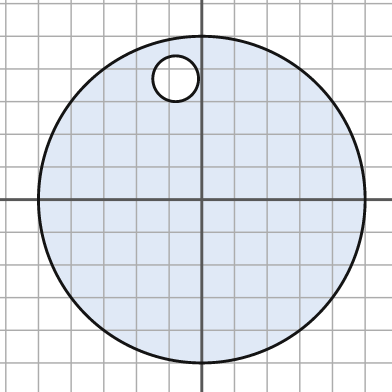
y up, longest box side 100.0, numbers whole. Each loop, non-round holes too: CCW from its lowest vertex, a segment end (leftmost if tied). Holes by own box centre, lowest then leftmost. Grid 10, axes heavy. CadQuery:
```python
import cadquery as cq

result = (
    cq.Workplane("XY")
    .moveTo(0.0, 0.0)
    .circle(50.0)
    .moveTo(-8.0, 37.0)
    .circle(7.0)
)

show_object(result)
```